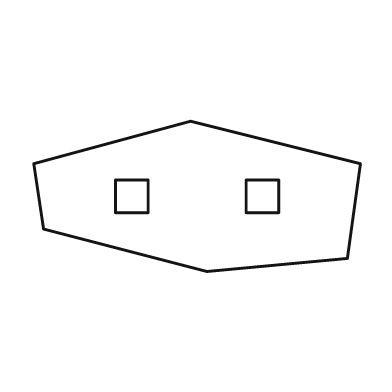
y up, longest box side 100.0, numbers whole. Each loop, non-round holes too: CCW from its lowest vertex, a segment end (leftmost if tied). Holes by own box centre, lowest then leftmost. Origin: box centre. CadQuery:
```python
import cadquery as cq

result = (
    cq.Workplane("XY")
    .moveTo(3.0, -23.0)
    .lineTo(46.0, -19.0)
    .lineTo(50.0, 10.0)
    .lineTo(-2.0, 23.0)
    .lineTo(-50.0, 10.0)
    .lineTo(-47.0, -10.0)
    .close()
    .moveTo(-25.0, -5.0)
    .lineTo(-15.0, -5.0)
    .lineTo(-15.0, 5.0)
    .lineTo(-25.0, 5.0)
    .close()
    .moveTo(15.0, -5.0)
    .lineTo(25.0, -5.0)
    .lineTo(25.0, 5.0)
    .lineTo(15.0, 5.0)
    .close()
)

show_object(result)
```